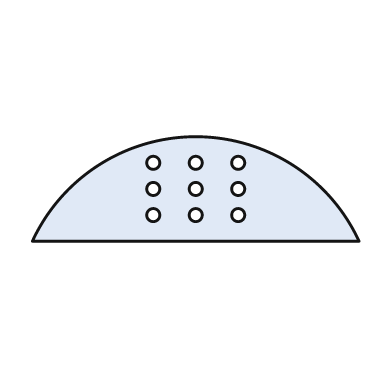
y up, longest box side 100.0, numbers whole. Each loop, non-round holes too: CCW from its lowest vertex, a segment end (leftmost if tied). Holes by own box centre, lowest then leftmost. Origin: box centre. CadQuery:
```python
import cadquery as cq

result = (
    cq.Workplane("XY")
    .moveTo(-50.0, -16.0)
    .lineTo(50.0, -16.0)
    .threePointArc((0.0, 16.0), (-50.0, -16.0))
    .close()
    .moveTo(-13.0, -8.0)
    .circle(2.0)
    .moveTo(0.0, -8.0)
    .circle(2.0)
    .moveTo(13.0, -8.0)
    .circle(2.0)
    .moveTo(-13.0, 0.0)
    .circle(2.0)
    .moveTo(0.0, 0.0)
    .circle(2.0)
    .moveTo(13.0, 0.0)
    .circle(2.0)
    .moveTo(-13.0, 8.0)
    .circle(2.0)
    .moveTo(0.0, 8.0)
    .circle(2.0)
    .moveTo(13.0, 8.0)
    .circle(2.0)
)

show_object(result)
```